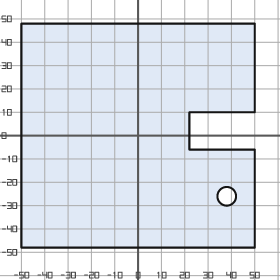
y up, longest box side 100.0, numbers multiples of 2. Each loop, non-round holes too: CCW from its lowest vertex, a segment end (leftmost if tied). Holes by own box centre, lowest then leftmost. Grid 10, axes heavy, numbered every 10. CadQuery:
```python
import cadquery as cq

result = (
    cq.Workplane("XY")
    .moveTo(-50.0, -48.0)
    .lineTo(50.0, -48.0)
    .lineTo(50.0, -6.0)
    .lineTo(22.0, -6.0)
    .lineTo(22.0, 10.0)
    .lineTo(50.0, 10.0)
    .lineTo(50.0, 48.0)
    .lineTo(-50.0, 48.0)
    .close()
    .moveTo(38.0, -26.0)
    .circle(4.0)
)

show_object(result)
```